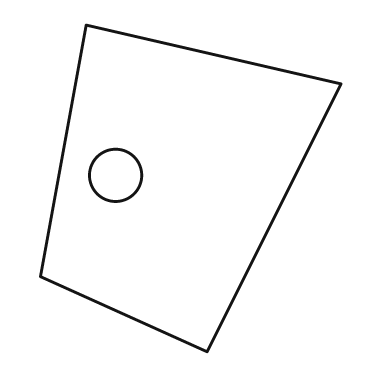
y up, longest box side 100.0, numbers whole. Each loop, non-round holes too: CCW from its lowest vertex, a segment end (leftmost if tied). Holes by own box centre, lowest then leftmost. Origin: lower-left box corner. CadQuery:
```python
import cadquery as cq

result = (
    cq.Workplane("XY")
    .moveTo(51.0, 0.0)
    .lineTo(92.0, 82.0)
    .lineTo(14.0, 100.0)
    .lineTo(0.0, 23.0)
    .close()
    .moveTo(23.0, 54.0)
    .circle(8.0)
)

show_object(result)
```